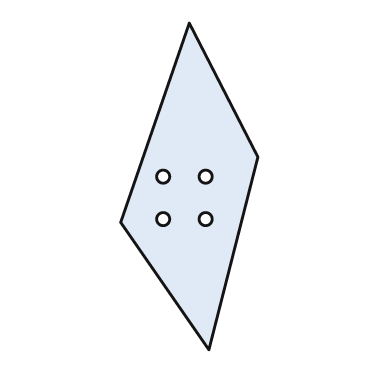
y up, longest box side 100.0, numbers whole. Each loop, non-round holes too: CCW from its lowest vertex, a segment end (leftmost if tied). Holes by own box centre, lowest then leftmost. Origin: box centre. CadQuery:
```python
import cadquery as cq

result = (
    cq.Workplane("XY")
    .moveTo(6.0, -50.0)
    .lineTo(21.0, 9.0)
    .lineTo(0.0, 50.0)
    .lineTo(-21.0, -11.0)
    .close()
    .moveTo(-8.0, -10.0)
    .circle(2.0)
    .moveTo(5.0, -10.0)
    .circle(2.0)
    .moveTo(-8.0, 3.0)
    .circle(2.0)
    .moveTo(5.0, 3.0)
    .circle(2.0)
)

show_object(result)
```